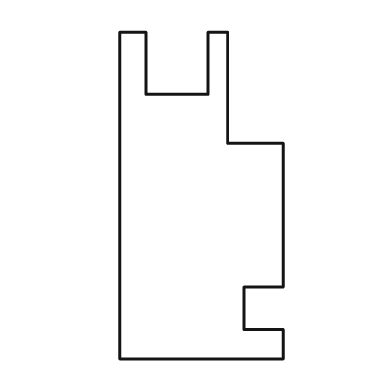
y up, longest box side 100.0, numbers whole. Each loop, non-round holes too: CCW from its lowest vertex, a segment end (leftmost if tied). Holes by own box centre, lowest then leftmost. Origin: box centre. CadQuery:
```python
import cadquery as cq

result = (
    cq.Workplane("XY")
    .moveTo(-25.0, -50.0)
    .lineTo(25.0, -50.0)
    .lineTo(25.0, -41.0)
    .lineTo(13.0, -41.0)
    .lineTo(13.0, -28.0)
    .lineTo(25.0, -28.0)
    .lineTo(25.0, 16.0)
    .lineTo(8.0, 16.0)
    .lineTo(8.0, 50.0)
    .lineTo(2.0, 50.0)
    .lineTo(2.0, 31.0)
    .lineTo(-17.0, 31.0)
    .lineTo(-17.0, 50.0)
    .lineTo(-25.0, 50.0)
    .close()
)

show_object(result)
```